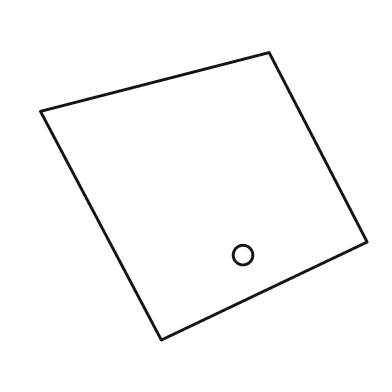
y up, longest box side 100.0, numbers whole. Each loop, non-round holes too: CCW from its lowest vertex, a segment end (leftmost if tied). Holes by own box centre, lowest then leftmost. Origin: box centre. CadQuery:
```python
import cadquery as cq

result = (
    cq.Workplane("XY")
    .moveTo(-13.0, -44.0)
    .lineTo(50.0, -14.0)
    .lineTo(20.0, 44.0)
    .lineTo(-50.0, 26.0)
    .close()
    .moveTo(12.0, -18.0)
    .circle(3.0)
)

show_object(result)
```